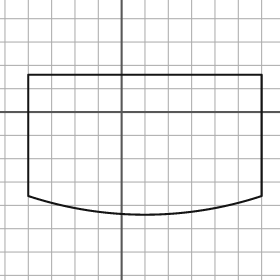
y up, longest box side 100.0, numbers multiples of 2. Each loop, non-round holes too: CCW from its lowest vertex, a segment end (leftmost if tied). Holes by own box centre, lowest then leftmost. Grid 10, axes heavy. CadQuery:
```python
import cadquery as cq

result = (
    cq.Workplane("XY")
    .moveTo(-40.0, -36.0)
    .threePointArc((10.0, -44.0), (60.0, -36.0))
    .lineTo(60.0, 16.0)
    .lineTo(-40.0, 16.0)
    .close()
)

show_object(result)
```